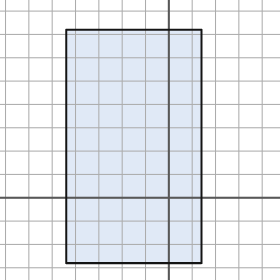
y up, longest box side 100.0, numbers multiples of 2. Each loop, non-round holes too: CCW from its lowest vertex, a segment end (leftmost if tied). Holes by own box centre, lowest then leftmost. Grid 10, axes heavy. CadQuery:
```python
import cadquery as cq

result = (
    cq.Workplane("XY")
    .moveTo(-44.0, -28.0)
    .lineTo(14.0, -28.0)
    .lineTo(14.0, 72.0)
    .lineTo(-44.0, 72.0)
    .close()
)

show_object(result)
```